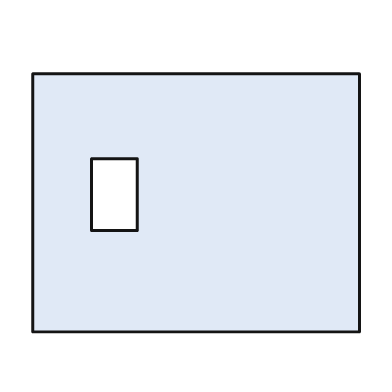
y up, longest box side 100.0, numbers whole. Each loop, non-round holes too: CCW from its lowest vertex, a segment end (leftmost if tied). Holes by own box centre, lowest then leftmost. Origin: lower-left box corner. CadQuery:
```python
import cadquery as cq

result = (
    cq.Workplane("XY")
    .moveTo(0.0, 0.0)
    .lineTo(100.0, 0.0)
    .lineTo(100.0, 79.0)
    .lineTo(0.0, 79.0)
    .close()
    .moveTo(18.0, 31.0)
    .lineTo(32.0, 31.0)
    .lineTo(32.0, 53.0)
    .lineTo(18.0, 53.0)
    .close()
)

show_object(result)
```